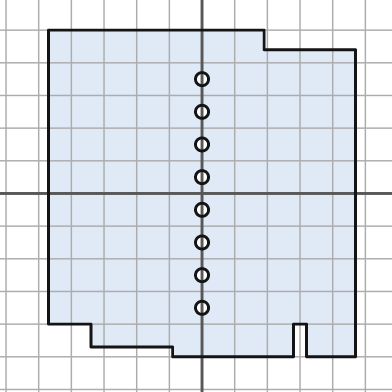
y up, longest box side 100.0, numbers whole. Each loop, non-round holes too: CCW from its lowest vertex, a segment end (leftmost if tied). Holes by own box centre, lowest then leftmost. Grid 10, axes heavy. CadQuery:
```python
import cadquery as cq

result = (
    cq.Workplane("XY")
    .moveTo(-9.0, -50.0)
    .lineTo(28.0, -50.0)
    .lineTo(28.0, -40.0)
    .lineTo(32.0, -40.0)
    .lineTo(32.0, -50.0)
    .lineTo(47.0, -50.0)
    .lineTo(47.0, 44.0)
    .lineTo(19.0, 44.0)
    .lineTo(19.0, 50.0)
    .lineTo(-47.0, 50.0)
    .lineTo(-47.0, -40.0)
    .lineTo(-34.0, -40.0)
    .lineTo(-34.0, -47.0)
    .lineTo(-9.0, -47.0)
    .close()
    .moveTo(0.0, -35.0)
    .circle(2.0)
    .moveTo(0.0, -25.0)
    .circle(2.0)
    .moveTo(0.0, -15.0)
    .circle(2.0)
    .moveTo(0.0, -5.0)
    .circle(2.0)
    .moveTo(0.0, 5.0)
    .circle(2.0)
    .moveTo(0.0, 15.0)
    .circle(2.0)
    .moveTo(0.0, 25.0)
    .circle(2.0)
    .moveTo(0.0, 35.0)
    .circle(2.0)
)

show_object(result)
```